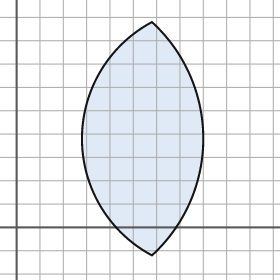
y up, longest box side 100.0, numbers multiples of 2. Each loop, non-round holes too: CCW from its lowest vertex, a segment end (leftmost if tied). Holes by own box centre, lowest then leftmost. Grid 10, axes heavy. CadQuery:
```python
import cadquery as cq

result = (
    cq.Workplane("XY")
    .moveTo(58.0, -12.0)
    .threePointArc((80.0, 38.0), (58.0, 88.0))
    .threePointArc((28.0, 38.0), (58.0, -12.0))
    .close()
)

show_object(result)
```